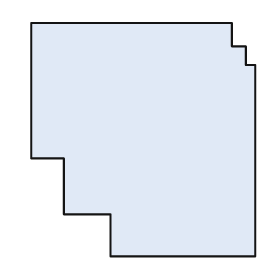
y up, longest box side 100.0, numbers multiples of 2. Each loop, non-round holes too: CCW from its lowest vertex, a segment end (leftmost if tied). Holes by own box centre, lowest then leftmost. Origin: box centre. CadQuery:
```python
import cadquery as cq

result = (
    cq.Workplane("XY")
    .moveTo(-14.0, -50.0)
    .lineTo(48.0, -50.0)
    .lineTo(48.0, 32.0)
    .lineTo(44.0, 32.0)
    .lineTo(44.0, 40.0)
    .lineTo(38.0, 40.0)
    .lineTo(38.0, 50.0)
    .lineTo(-48.0, 50.0)
    .lineTo(-48.0, -8.0)
    .lineTo(-34.0, -8.0)
    .lineTo(-34.0, -32.0)
    .lineTo(-14.0, -32.0)
    .close()
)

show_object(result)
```